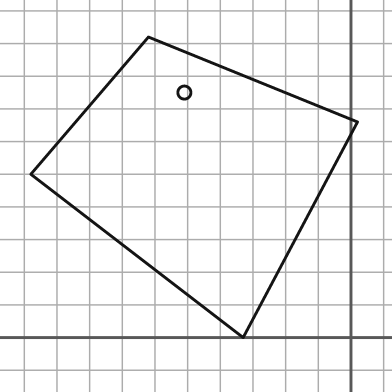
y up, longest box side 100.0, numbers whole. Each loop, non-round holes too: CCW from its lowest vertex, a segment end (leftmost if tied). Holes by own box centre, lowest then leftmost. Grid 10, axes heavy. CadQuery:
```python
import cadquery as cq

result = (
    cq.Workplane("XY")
    .moveTo(-33.0, 0.0)
    .lineTo(2.0, 66.0)
    .lineTo(-62.0, 92.0)
    .lineTo(-98.0, 50.0)
    .close()
    .moveTo(-51.0, 75.0)
    .circle(2.0)
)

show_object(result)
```